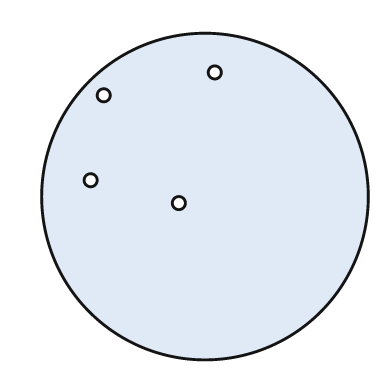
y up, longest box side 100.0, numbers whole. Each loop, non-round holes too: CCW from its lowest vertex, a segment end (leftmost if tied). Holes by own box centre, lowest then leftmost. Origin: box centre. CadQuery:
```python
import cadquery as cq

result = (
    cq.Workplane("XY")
    .moveTo(0.0, 0.0)
    .circle(50.0)
    .moveTo(-8.0, -2.0)
    .circle(2.0)
    .moveTo(-35.0, 5.0)
    .circle(2.0)
    .moveTo(-31.0, 31.0)
    .circle(2.0)
    .moveTo(3.0, 38.0)
    .circle(2.0)
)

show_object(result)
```